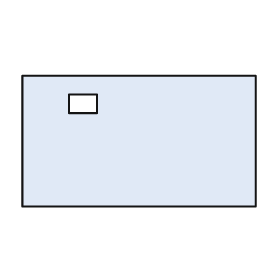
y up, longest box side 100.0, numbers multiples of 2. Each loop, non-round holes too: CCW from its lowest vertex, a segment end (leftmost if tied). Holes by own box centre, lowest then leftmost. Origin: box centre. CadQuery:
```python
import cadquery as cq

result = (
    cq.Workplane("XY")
    .moveTo(-50.0, -28.0)
    .lineTo(50.0, -28.0)
    .lineTo(50.0, 28.0)
    .lineTo(-50.0, 28.0)
    .close()
    .moveTo(-30.0, 12.0)
    .lineTo(-18.0, 12.0)
    .lineTo(-18.0, 20.0)
    .lineTo(-30.0, 20.0)
    .close()
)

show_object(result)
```